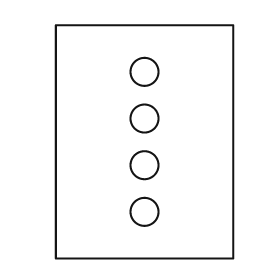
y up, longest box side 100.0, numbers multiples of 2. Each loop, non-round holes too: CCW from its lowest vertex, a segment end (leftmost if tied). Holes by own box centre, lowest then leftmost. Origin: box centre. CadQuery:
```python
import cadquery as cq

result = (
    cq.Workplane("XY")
    .moveTo(-38.0, -50.0)
    .lineTo(38.0, -50.0)
    .lineTo(38.0, 50.0)
    .lineTo(-38.0, 50.0)
    .close()
    .moveTo(0.0, -30.0)
    .circle(6.0)
    .moveTo(0.0, -10.0)
    .circle(6.0)
    .moveTo(0.0, 10.0)
    .circle(6.0)
    .moveTo(0.0, 30.0)
    .circle(6.0)
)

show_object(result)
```